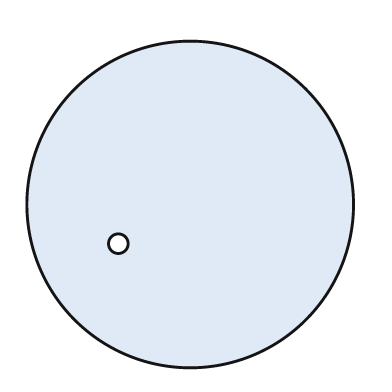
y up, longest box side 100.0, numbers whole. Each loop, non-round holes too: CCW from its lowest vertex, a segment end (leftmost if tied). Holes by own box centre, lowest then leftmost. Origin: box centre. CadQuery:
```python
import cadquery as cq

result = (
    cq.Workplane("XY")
    .moveTo(0.0, 0.0)
    .circle(50.0)
    .moveTo(-22.0, -12.0)
    .circle(3.0)
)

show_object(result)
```